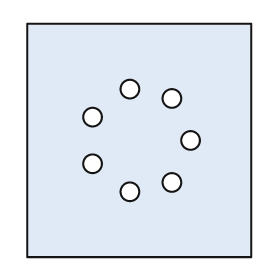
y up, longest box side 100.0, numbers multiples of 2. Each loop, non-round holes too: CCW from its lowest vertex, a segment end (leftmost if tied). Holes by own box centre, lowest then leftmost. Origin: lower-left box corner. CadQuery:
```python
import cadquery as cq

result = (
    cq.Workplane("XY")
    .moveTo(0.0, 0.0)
    .lineTo(96.0, 0.0)
    .lineTo(96.0, 100.0)
    .lineTo(0.0, 100.0)
    .close()
    .moveTo(44.0, 28.0)
    .circle(4.0)
    .moveTo(62.0, 32.0)
    .circle(4.0)
    .moveTo(28.0, 40.0)
    .circle(4.0)
    .moveTo(70.0, 50.0)
    .circle(4.0)
    .moveTo(28.0, 60.0)
    .circle(4.0)
    .moveTo(62.0, 68.0)
    .circle(4.0)
    .moveTo(44.0, 72.0)
    .circle(4.0)
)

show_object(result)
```